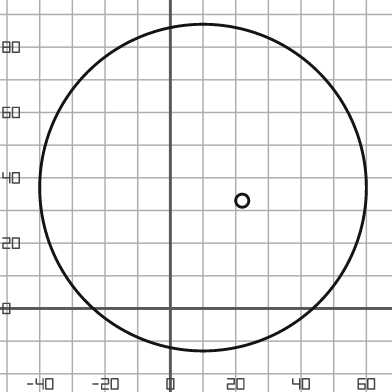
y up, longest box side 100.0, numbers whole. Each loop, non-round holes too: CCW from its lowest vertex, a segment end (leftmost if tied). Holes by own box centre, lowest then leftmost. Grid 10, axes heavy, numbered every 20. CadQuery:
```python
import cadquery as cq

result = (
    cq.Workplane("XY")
    .moveTo(10.0, 37.0)
    .circle(50.0)
    .moveTo(22.0, 33.0)
    .circle(2.0)
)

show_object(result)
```